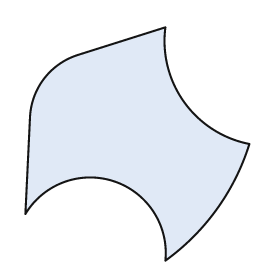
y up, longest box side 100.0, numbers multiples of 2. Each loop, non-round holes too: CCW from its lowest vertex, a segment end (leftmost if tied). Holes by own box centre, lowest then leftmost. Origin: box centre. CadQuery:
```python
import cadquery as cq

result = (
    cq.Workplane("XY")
    .moveTo(12.0, -50.0)
    .threePointArc((34.0, -28.0), (48.0, 0.0))
    .threePointArc((20.0, 18.0), (12.0, 50.0))
    .lineTo(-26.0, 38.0)
    .threePointArc((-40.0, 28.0), (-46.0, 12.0))
    .lineTo(-48.0, -30.0)
    .threePointArc((-10.0, -16.0), (12.0, -50.0))
    .close()
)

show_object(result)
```